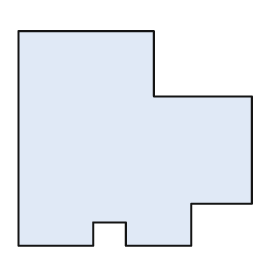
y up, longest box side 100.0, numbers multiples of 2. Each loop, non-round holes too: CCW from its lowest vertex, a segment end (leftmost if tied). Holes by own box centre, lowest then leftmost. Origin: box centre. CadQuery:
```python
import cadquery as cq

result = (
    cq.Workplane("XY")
    .moveTo(-50.0, -46.0)
    .lineTo(-18.0, -46.0)
    .lineTo(-18.0, -36.0)
    .lineTo(-4.0, -36.0)
    .lineTo(-4.0, -46.0)
    .lineTo(24.0, -46.0)
    .lineTo(24.0, -28.0)
    .lineTo(50.0, -28.0)
    .lineTo(50.0, 18.0)
    .lineTo(8.0, 18.0)
    .lineTo(8.0, 46.0)
    .lineTo(-50.0, 46.0)
    .close()
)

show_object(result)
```